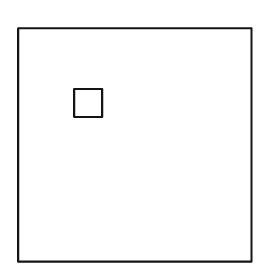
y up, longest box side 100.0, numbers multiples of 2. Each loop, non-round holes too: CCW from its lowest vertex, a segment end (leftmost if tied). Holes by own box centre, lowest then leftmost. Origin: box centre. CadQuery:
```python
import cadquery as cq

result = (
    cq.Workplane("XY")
    .moveTo(-50.0, -50.0)
    .lineTo(50.0, -50.0)
    .lineTo(50.0, 50.0)
    .lineTo(-50.0, 50.0)
    .close()
    .moveTo(-26.0, 12.0)
    .lineTo(-14.0, 12.0)
    .lineTo(-14.0, 24.0)
    .lineTo(-26.0, 24.0)
    .close()
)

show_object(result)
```